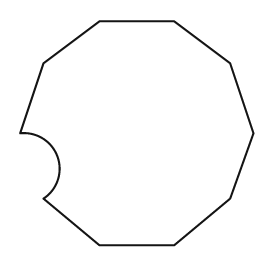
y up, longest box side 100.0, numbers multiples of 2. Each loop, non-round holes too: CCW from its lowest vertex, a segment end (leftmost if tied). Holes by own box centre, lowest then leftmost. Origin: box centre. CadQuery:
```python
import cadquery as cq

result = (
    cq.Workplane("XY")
    .moveTo(-16.0, -48.0)
    .lineTo(16.0, -48.0)
    .lineTo(40.0, -28.0)
    .lineTo(50.0, 0.0)
    .lineTo(40.0, 30.0)
    .lineTo(16.0, 48.0)
    .lineTo(-16.0, 48.0)
    .lineTo(-40.0, 30.0)
    .lineTo(-50.0, 0.0)
    .threePointArc((-34.0, -10.0), (-40.0, -28.0))
    .close()
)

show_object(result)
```